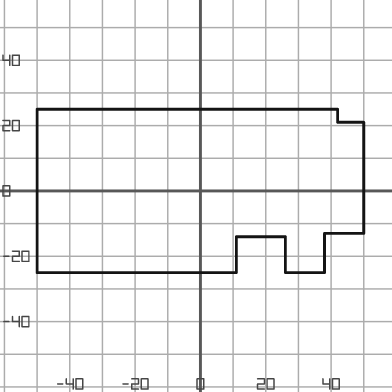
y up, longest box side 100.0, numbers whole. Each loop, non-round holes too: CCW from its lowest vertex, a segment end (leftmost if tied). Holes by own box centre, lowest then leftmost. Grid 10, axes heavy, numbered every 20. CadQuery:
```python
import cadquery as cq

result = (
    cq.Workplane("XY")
    .moveTo(-50.0, -25.0)
    .lineTo(11.0, -25.0)
    .lineTo(11.0, -14.0)
    .lineTo(26.0, -14.0)
    .lineTo(26.0, -25.0)
    .lineTo(38.0, -25.0)
    .lineTo(38.0, -13.0)
    .lineTo(50.0, -13.0)
    .lineTo(50.0, 21.0)
    .lineTo(42.0, 21.0)
    .lineTo(42.0, 25.0)
    .lineTo(-50.0, 25.0)
    .close()
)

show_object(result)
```